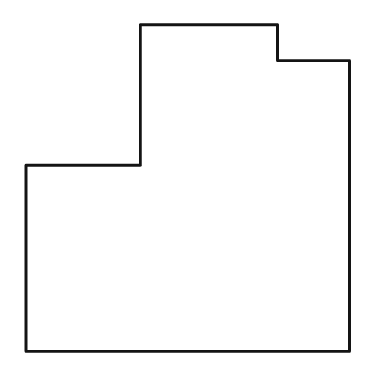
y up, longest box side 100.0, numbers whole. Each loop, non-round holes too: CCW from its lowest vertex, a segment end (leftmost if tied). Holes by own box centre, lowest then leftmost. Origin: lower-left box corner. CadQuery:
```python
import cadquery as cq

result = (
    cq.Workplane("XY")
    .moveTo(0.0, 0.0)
    .lineTo(99.0, 0.0)
    .lineTo(99.0, 89.0)
    .lineTo(77.0, 89.0)
    .lineTo(77.0, 100.0)
    .lineTo(35.0, 100.0)
    .lineTo(35.0, 57.0)
    .lineTo(0.0, 57.0)
    .close()
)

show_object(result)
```